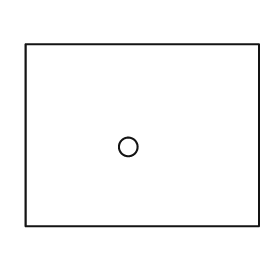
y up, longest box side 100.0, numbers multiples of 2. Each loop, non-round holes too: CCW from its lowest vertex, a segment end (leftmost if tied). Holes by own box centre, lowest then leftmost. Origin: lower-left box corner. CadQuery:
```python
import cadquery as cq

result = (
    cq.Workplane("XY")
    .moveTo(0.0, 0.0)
    .lineTo(100.0, 0.0)
    .lineTo(100.0, 78.0)
    .lineTo(0.0, 78.0)
    .close()
    .moveTo(44.0, 34.0)
    .circle(4.0)
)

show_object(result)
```